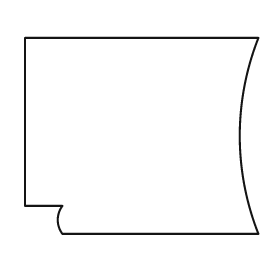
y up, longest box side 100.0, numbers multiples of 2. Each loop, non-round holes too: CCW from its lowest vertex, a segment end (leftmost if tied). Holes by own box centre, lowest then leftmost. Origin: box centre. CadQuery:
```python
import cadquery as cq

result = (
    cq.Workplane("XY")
    .moveTo(-34.0, -42.0)
    .lineTo(50.0, -42.0)
    .threePointArc((42.0, 0.0), (50.0, 42.0))
    .lineTo(-50.0, 42.0)
    .lineTo(-50.0, -30.0)
    .lineTo(-34.0, -30.0)
    .threePointArc((-36.0, -36.0), (-34.0, -42.0))
    .close()
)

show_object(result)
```